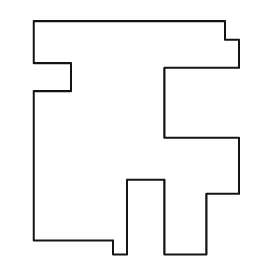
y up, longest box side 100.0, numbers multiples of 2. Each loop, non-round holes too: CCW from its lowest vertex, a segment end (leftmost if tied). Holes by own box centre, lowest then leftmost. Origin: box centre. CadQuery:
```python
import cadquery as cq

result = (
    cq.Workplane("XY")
    .moveTo(-10.0, -50.0)
    .lineTo(-4.0, -50.0)
    .lineTo(-4.0, -18.0)
    .lineTo(12.0, -18.0)
    .lineTo(12.0, -50.0)
    .lineTo(30.0, -50.0)
    .lineTo(30.0, -24.0)
    .lineTo(44.0, -24.0)
    .lineTo(44.0, 0.0)
    .lineTo(12.0, 0.0)
    .lineTo(12.0, 30.0)
    .lineTo(44.0, 30.0)
    .lineTo(44.0, 42.0)
    .lineTo(38.0, 42.0)
    .lineTo(38.0, 50.0)
    .lineTo(-44.0, 50.0)
    .lineTo(-44.0, 32.0)
    .lineTo(-28.0, 32.0)
    .lineTo(-28.0, 20.0)
    .lineTo(-44.0, 20.0)
    .lineTo(-44.0, -44.0)
    .lineTo(-10.0, -44.0)
    .close()
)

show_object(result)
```